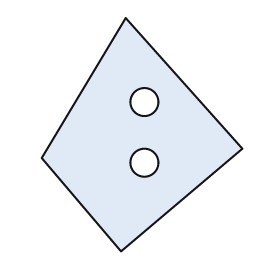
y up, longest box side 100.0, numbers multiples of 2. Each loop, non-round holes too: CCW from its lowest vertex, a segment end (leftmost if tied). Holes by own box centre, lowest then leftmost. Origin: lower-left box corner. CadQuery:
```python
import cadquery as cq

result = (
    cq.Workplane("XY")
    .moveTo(34.0, 0.0)
    .lineTo(86.0, 44.0)
    .lineTo(36.0, 100.0)
    .lineTo(0.0, 40.0)
    .close()
    .moveTo(44.0, 38.0)
    .circle(6.0)
    .moveTo(44.0, 64.0)
    .circle(6.0)
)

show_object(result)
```